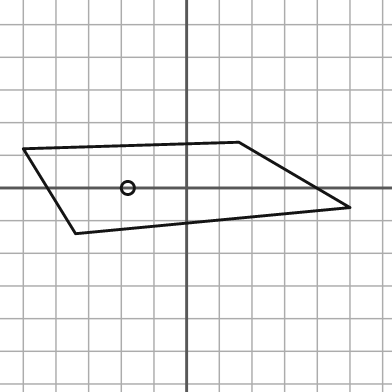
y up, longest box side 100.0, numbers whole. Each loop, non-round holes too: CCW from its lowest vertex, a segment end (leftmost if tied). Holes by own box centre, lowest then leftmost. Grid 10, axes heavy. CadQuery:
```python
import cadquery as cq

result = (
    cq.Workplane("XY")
    .moveTo(-34.0, -14.0)
    .lineTo(50.0, -6.0)
    .lineTo(16.0, 14.0)
    .lineTo(-50.0, 12.0)
    .close()
    .moveTo(-18.0, 0.0)
    .circle(2.0)
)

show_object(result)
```